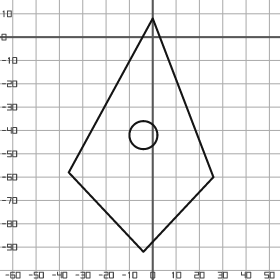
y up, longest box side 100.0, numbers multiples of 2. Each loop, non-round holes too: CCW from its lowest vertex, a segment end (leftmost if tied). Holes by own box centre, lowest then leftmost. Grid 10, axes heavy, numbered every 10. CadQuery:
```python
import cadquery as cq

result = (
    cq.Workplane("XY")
    .moveTo(-4.0, -92.0)
    .lineTo(26.0, -60.0)
    .lineTo(0.0, 8.0)
    .lineTo(-36.0, -58.0)
    .close()
    .moveTo(-4.0, -42.0)
    .circle(6.0)
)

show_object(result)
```